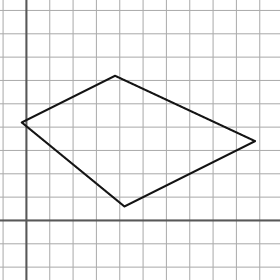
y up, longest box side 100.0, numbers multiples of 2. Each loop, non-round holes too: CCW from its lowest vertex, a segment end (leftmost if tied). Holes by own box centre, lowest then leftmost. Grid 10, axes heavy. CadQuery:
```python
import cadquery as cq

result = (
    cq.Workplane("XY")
    .moveTo(42.0, 6.0)
    .lineTo(98.0, 34.0)
    .lineTo(38.0, 62.0)
    .lineTo(-2.0, 42.0)
    .close()
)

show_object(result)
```